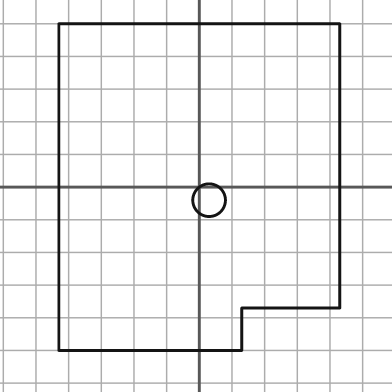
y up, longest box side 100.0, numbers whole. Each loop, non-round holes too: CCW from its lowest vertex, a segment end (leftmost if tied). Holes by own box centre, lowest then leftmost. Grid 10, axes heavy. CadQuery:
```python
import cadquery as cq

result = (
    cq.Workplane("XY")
    .moveTo(-43.0, -50.0)
    .lineTo(13.0, -50.0)
    .lineTo(13.0, -37.0)
    .lineTo(43.0, -37.0)
    .lineTo(43.0, 50.0)
    .lineTo(-43.0, 50.0)
    .close()
    .moveTo(3.0, -4.0)
    .circle(5.0)
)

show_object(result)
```